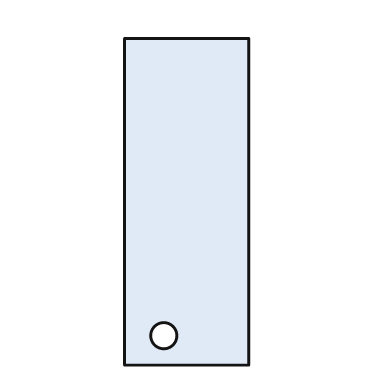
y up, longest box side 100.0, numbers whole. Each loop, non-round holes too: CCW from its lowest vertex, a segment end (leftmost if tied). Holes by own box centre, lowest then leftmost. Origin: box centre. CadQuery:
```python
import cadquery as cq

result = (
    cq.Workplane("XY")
    .moveTo(-19.0, -50.0)
    .lineTo(19.0, -50.0)
    .lineTo(19.0, 50.0)
    .lineTo(-19.0, 50.0)
    .close()
    .moveTo(-7.0, -41.0)
    .circle(4.0)
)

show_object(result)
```